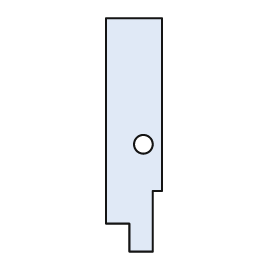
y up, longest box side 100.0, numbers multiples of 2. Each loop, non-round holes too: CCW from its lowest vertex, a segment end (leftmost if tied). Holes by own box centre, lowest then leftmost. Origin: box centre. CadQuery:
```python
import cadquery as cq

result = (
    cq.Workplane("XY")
    .moveTo(-2.0, -50.0)
    .lineTo(8.0, -50.0)
    .lineTo(8.0, -24.0)
    .lineTo(12.0, -24.0)
    .lineTo(12.0, 50.0)
    .lineTo(-12.0, 50.0)
    .lineTo(-12.0, -38.0)
    .lineTo(-2.0, -38.0)
    .close()
    .moveTo(4.0, -4.0)
    .circle(4.0)
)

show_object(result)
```